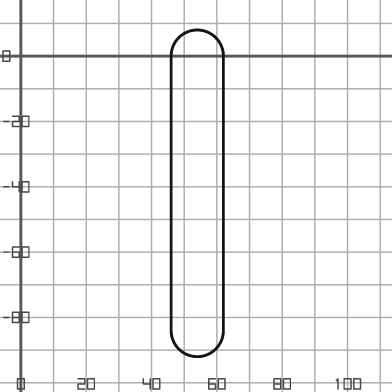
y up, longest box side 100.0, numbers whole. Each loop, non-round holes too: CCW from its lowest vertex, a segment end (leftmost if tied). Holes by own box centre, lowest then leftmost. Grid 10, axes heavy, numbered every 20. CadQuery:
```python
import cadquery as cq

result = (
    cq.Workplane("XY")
    .moveTo(46.0, -84.0)
    .threePointArc((54.0, -92.0), (62.0, -84.0))
    .lineTo(62.0, 0.0)
    .threePointArc((54.0, 8.0), (46.0, 0.0))
    .close()
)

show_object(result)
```